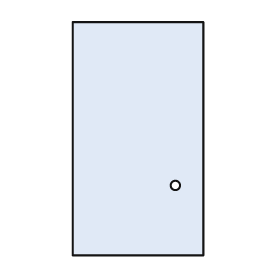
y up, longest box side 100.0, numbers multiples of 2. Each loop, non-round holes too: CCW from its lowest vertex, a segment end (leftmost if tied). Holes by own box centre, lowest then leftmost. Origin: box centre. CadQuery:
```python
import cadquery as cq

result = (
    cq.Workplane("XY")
    .moveTo(-28.0, -50.0)
    .lineTo(28.0, -50.0)
    .lineTo(28.0, 50.0)
    .lineTo(-28.0, 50.0)
    .close()
    .moveTo(16.0, -20.0)
    .circle(2.0)
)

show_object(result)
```